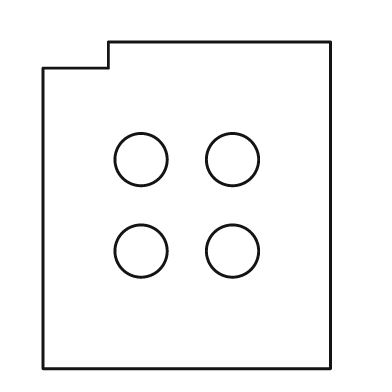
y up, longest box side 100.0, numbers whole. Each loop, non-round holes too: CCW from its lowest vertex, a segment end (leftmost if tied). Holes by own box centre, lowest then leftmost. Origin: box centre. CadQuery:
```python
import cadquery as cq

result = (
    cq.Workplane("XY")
    .moveTo(-44.0, -50.0)
    .lineTo(44.0, -50.0)
    .lineTo(44.0, 50.0)
    .lineTo(-24.0, 50.0)
    .lineTo(-24.0, 42.0)
    .lineTo(-44.0, 42.0)
    .close()
    .moveTo(-14.0, -14.0)
    .circle(8.0)
    .moveTo(14.0, -14.0)
    .circle(8.0)
    .moveTo(-14.0, 14.0)
    .circle(8.0)
    .moveTo(14.0, 14.0)
    .circle(8.0)
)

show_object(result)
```